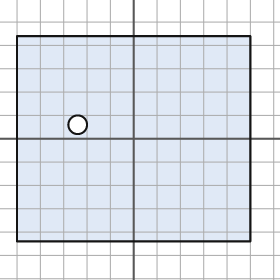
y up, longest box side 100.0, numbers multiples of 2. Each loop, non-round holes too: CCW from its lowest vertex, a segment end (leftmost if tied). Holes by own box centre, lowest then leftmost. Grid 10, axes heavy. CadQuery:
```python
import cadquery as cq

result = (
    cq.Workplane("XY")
    .moveTo(-50.0, -44.0)
    .lineTo(50.0, -44.0)
    .lineTo(50.0, 44.0)
    .lineTo(-50.0, 44.0)
    .close()
    .moveTo(-24.0, 6.0)
    .circle(4.0)
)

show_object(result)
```